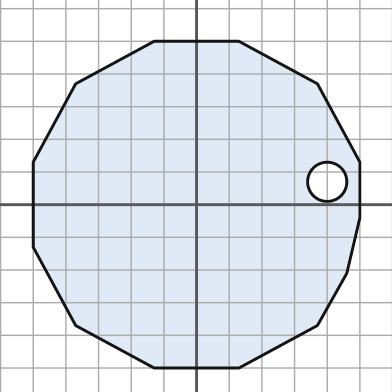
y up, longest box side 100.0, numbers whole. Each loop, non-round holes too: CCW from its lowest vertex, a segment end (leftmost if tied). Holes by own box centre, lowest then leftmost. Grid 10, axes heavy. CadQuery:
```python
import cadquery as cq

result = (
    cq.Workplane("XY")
    .moveTo(-13.0, -50.0)
    .lineTo(13.0, -50.0)
    .lineTo(37.0, -37.0)
    .lineTo(46.0, -21.0)
    .lineTo(50.0, -4.0)
    .lineTo(50.0, 13.0)
    .lineTo(37.0, 37.0)
    .lineTo(13.0, 50.0)
    .lineTo(-13.0, 50.0)
    .lineTo(-37.0, 37.0)
    .lineTo(-50.0, 13.0)
    .lineTo(-50.0, -13.0)
    .lineTo(-37.0, -37.0)
    .close()
    .moveTo(40.0, 7.0)
    .circle(6.0)
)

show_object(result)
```